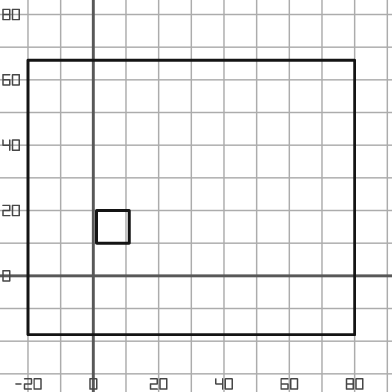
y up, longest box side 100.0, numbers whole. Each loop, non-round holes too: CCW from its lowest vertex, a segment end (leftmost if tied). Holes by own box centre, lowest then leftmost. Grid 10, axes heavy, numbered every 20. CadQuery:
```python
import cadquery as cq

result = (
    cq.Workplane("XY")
    .moveTo(-20.0, -18.0)
    .lineTo(80.0, -18.0)
    .lineTo(80.0, 66.0)
    .lineTo(-20.0, 66.0)
    .close()
    .moveTo(1.0, 10.0)
    .lineTo(11.0, 10.0)
    .lineTo(11.0, 20.0)
    .lineTo(1.0, 20.0)
    .close()
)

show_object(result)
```